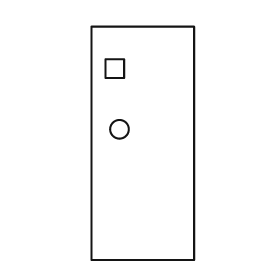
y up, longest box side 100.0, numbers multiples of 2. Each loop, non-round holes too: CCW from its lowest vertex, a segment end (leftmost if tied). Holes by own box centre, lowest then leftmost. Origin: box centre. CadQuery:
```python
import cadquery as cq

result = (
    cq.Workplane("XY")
    .moveTo(-22.0, -50.0)
    .lineTo(22.0, -50.0)
    .lineTo(22.0, 50.0)
    .lineTo(-22.0, 50.0)
    .close()
    .moveTo(-10.0, 6.0)
    .circle(4.0)
    .moveTo(-16.0, 28.0)
    .lineTo(-8.0, 28.0)
    .lineTo(-8.0, 36.0)
    .lineTo(-16.0, 36.0)
    .close()
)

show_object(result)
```